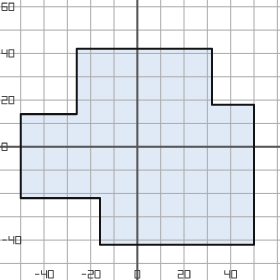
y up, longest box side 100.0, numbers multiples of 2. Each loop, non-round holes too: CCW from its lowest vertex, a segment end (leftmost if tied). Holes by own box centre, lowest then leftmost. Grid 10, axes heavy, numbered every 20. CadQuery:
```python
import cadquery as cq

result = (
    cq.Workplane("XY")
    .moveTo(-16.0, -42.0)
    .lineTo(50.0, -42.0)
    .lineTo(50.0, 18.0)
    .lineTo(32.0, 18.0)
    .lineTo(32.0, 42.0)
    .lineTo(-26.0, 42.0)
    .lineTo(-26.0, 14.0)
    .lineTo(-50.0, 14.0)
    .lineTo(-50.0, -22.0)
    .lineTo(-16.0, -22.0)
    .close()
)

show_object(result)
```